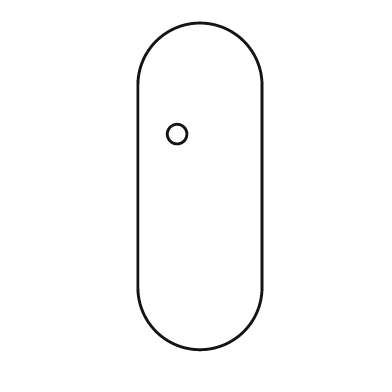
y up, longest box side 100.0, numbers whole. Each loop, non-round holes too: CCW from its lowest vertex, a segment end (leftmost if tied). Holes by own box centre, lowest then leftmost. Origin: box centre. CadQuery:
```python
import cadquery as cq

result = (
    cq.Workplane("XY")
    .moveTo(-19.0, -31.0)
    .threePointArc((0.0, -50.0), (19.0, -31.0))
    .lineTo(19.0, 31.0)
    .threePointArc((0.0, 50.0), (-19.0, 31.0))
    .close()
    .moveTo(-7.0, 16.0)
    .circle(3.0)
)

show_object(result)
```